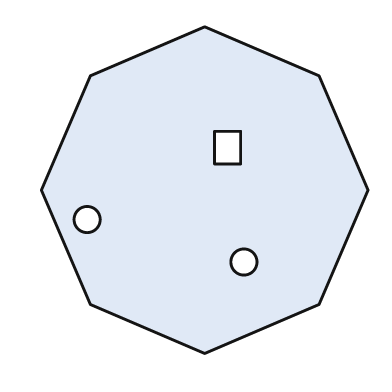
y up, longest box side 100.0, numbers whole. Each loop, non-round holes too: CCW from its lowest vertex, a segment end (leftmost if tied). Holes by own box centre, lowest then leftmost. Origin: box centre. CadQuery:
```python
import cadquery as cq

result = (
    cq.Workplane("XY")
    .moveTo(0.0, -50.0)
    .lineTo(35.0, -35.0)
    .lineTo(50.0, 0.0)
    .lineTo(35.0, 35.0)
    .lineTo(0.0, 50.0)
    .lineTo(-35.0, 35.0)
    .lineTo(-50.0, 0.0)
    .lineTo(-35.0, -35.0)
    .close()
    .moveTo(12.0, -22.0)
    .circle(4.0)
    .moveTo(-36.0, -9.0)
    .circle(4.0)
    .moveTo(3.0, 8.0)
    .lineTo(11.0, 8.0)
    .lineTo(11.0, 18.0)
    .lineTo(3.0, 18.0)
    .close()
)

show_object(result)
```